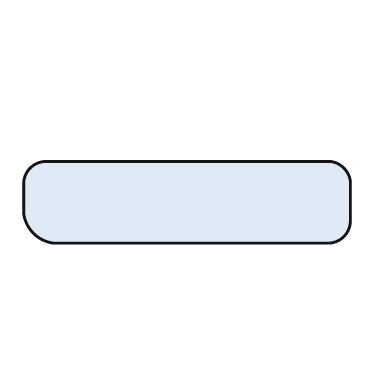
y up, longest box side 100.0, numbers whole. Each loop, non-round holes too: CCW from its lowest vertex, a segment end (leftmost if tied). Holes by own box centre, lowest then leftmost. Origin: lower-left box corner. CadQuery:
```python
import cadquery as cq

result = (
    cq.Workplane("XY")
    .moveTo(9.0, 0.0)
    .lineTo(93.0, 0.0)
    .threePointArc((98.0, 2.0), (100.0, 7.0))
    .lineTo(100.0, 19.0)
    .threePointArc((98.0, 23.0), (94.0, 25.0))
    .lineTo(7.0, 25.0)
    .threePointArc((2.0, 23.0), (0.0, 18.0))
    .lineTo(0.0, 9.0)
    .threePointArc((3.0, 3.0), (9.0, 0.0))
    .close()
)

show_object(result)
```